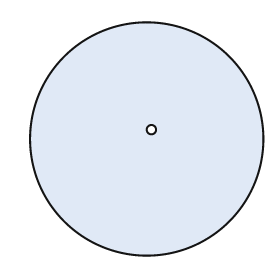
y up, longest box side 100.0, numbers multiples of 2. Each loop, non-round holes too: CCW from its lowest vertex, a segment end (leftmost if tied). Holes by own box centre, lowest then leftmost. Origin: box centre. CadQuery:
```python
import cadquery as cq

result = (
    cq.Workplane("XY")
    .moveTo(0.0, 0.0)
    .circle(50.0)
    .moveTo(2.0, 4.0)
    .circle(2.0)
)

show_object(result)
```